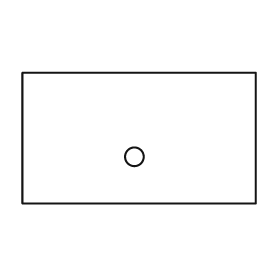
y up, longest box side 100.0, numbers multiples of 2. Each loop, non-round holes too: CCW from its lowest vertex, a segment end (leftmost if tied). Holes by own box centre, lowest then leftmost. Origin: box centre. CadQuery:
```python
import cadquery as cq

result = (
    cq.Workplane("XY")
    .moveTo(-50.0, -28.0)
    .lineTo(50.0, -28.0)
    .lineTo(50.0, 28.0)
    .lineTo(-50.0, 28.0)
    .close()
    .moveTo(-2.0, -8.0)
    .circle(4.0)
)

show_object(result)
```